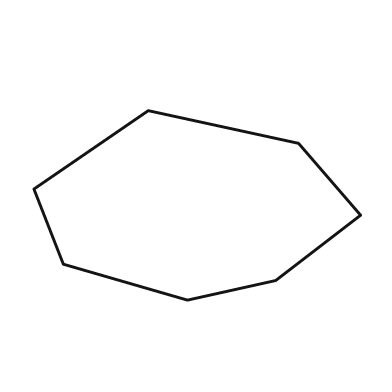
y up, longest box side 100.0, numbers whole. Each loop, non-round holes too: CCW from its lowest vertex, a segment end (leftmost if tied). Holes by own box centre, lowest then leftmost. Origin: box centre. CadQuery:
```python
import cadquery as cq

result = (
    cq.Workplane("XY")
    .moveTo(-3.0, -29.0)
    .lineTo(24.0, -23.0)
    .lineTo(50.0, -3.0)
    .lineTo(31.0, 19.0)
    .lineTo(-15.0, 29.0)
    .lineTo(-50.0, 5.0)
    .lineTo(-41.0, -18.0)
    .close()
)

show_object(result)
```